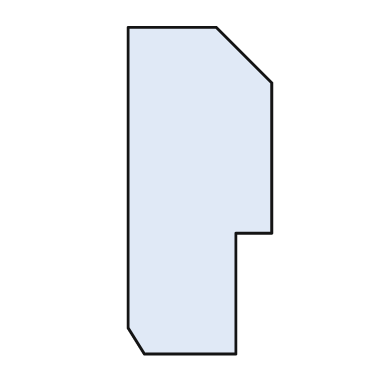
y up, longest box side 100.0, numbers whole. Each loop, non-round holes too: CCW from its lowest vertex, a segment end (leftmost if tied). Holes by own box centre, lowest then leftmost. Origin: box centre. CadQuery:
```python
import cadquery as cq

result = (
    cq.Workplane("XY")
    .moveTo(-17.0, -50.0)
    .lineTo(11.0, -50.0)
    .lineTo(11.0, -13.0)
    .lineTo(22.0, -13.0)
    .lineTo(22.0, 33.0)
    .lineTo(5.0, 50.0)
    .lineTo(-22.0, 50.0)
    .lineTo(-22.0, -42.0)
    .close()
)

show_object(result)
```